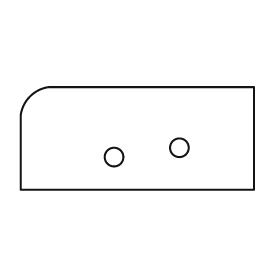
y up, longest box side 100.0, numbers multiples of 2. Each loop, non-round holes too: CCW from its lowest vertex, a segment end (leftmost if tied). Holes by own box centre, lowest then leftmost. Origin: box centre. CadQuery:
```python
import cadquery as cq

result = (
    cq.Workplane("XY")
    .moveTo(-50.0, -22.0)
    .lineTo(50.0, -22.0)
    .lineTo(50.0, 22.0)
    .lineTo(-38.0, 22.0)
    .threePointArc((-46.0, 18.0), (-50.0, 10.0))
    .close()
    .moveTo(-10.0, -8.0)
    .circle(4.0)
    .moveTo(18.0, -4.0)
    .circle(4.0)
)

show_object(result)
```